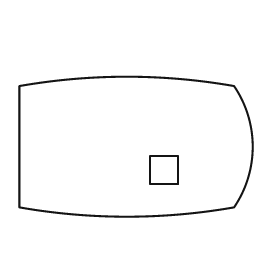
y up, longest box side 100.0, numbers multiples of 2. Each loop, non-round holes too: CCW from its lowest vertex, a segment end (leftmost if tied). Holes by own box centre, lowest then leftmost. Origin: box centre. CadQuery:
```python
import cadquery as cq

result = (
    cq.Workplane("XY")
    .moveTo(-50.0, -26.0)
    .threePointArc((-4.0, -30.0), (42.0, -26.0))
    .threePointArc((50.0, 0.0), (42.0, 26.0))
    .threePointArc((-4.0, 30.0), (-50.0, 26.0))
    .close()
    .moveTo(6.0, -16.0)
    .lineTo(18.0, -16.0)
    .lineTo(18.0, -4.0)
    .lineTo(6.0, -4.0)
    .close()
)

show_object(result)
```